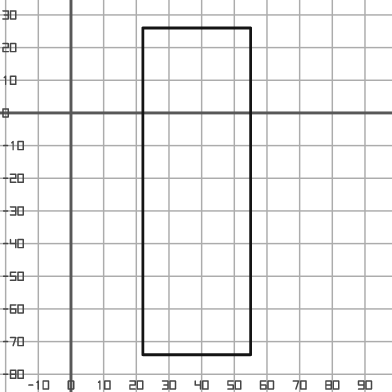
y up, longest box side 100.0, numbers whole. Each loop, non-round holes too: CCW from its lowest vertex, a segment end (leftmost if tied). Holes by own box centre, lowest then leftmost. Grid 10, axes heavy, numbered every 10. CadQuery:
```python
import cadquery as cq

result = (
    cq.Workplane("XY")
    .moveTo(22.0, -74.0)
    .lineTo(55.0, -74.0)
    .lineTo(55.0, 26.0)
    .lineTo(22.0, 26.0)
    .close()
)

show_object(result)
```